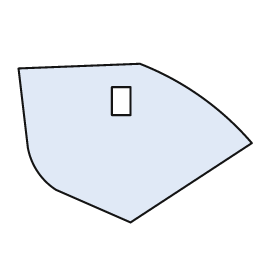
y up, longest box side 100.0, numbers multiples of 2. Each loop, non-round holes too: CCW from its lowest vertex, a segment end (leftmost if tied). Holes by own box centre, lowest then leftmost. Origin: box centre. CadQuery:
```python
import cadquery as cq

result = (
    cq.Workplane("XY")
    .moveTo(-2.0, -34.0)
    .lineTo(50.0, 0.0)
    .threePointArc((28.0, 20.0), (2.0, 34.0))
    .lineTo(-50.0, 32.0)
    .lineTo(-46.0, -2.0)
    .threePointArc((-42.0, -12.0), (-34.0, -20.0))
    .close()
    .moveTo(-10.0, 12.0)
    .lineTo(-2.0, 12.0)
    .lineTo(-2.0, 24.0)
    .lineTo(-10.0, 24.0)
    .close()
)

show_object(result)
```